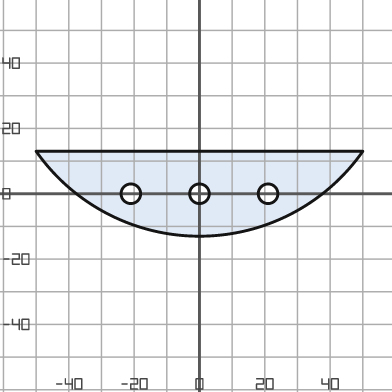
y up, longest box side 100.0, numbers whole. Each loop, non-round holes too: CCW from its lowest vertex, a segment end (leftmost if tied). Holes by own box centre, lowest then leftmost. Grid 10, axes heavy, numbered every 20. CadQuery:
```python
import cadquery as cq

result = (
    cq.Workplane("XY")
    .moveTo(-50.0, 13.0)
    .threePointArc((0.0, -13.0), (50.0, 13.0))
    .close()
    .moveTo(-21.0, 0.0)
    .circle(3.0)
    .moveTo(0.0, 0.0)
    .circle(3.0)
    .moveTo(21.0, 0.0)
    .circle(3.0)
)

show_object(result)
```